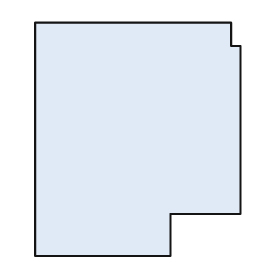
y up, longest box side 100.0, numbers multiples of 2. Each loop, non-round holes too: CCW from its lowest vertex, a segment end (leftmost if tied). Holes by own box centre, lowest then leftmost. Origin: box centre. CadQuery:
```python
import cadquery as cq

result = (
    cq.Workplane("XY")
    .moveTo(-44.0, -50.0)
    .lineTo(14.0, -50.0)
    .lineTo(14.0, -32.0)
    .lineTo(44.0, -32.0)
    .lineTo(44.0, 40.0)
    .lineTo(40.0, 40.0)
    .lineTo(40.0, 50.0)
    .lineTo(-44.0, 50.0)
    .close()
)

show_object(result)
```